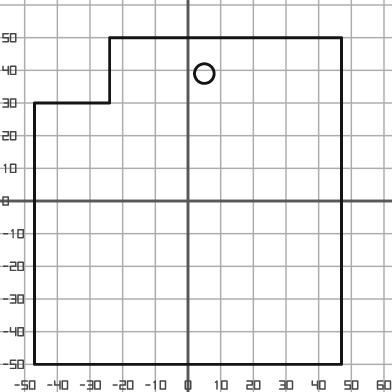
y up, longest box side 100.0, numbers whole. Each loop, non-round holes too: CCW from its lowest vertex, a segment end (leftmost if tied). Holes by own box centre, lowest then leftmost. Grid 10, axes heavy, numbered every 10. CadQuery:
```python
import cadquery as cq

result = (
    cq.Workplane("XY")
    .moveTo(-47.0, -50.0)
    .lineTo(47.0, -50.0)
    .lineTo(47.0, 50.0)
    .lineTo(-24.0, 50.0)
    .lineTo(-24.0, 30.0)
    .lineTo(-47.0, 30.0)
    .close()
    .moveTo(5.0, 39.0)
    .circle(3.0)
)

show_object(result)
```